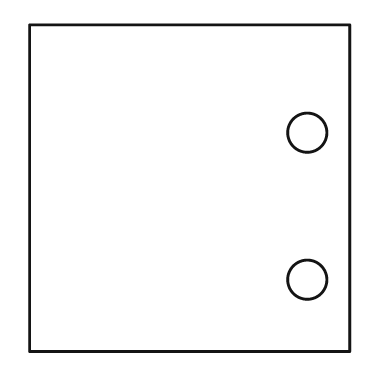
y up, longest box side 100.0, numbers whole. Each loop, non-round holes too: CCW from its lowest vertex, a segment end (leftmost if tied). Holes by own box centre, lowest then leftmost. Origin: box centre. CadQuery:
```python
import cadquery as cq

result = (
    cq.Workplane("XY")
    .moveTo(-49.0, -50.0)
    .lineTo(49.0, -50.0)
    .lineTo(49.0, 50.0)
    .lineTo(-49.0, 50.0)
    .close()
    .moveTo(36.0, -28.0)
    .circle(6.0)
    .moveTo(36.0, 17.0)
    .circle(6.0)
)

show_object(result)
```